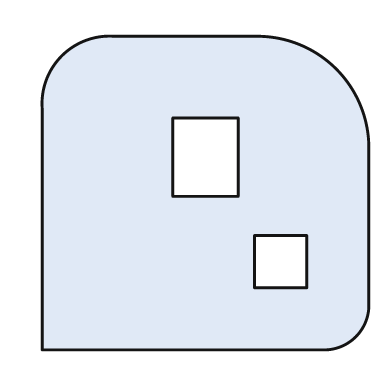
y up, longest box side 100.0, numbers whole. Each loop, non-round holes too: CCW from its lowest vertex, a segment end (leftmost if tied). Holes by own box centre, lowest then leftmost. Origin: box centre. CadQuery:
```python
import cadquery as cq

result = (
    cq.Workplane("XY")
    .moveTo(-50.0, -48.0)
    .lineTo(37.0, -48.0)
    .threePointArc((46.0, -44.0), (50.0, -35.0))
    .lineTo(50.0, 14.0)
    .threePointArc((40.0, 38.0), (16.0, 48.0))
    .lineTo(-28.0, 48.0)
    .threePointArc((-44.0, 42.0), (-50.0, 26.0))
    .close()
    .moveTo(15.0, -29.0)
    .lineTo(31.0, -29.0)
    .lineTo(31.0, -13.0)
    .lineTo(15.0, -13.0)
    .close()
    .moveTo(-10.0, -1.0)
    .lineTo(10.0, -1.0)
    .lineTo(10.0, 23.0)
    .lineTo(-10.0, 23.0)
    .close()
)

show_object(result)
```